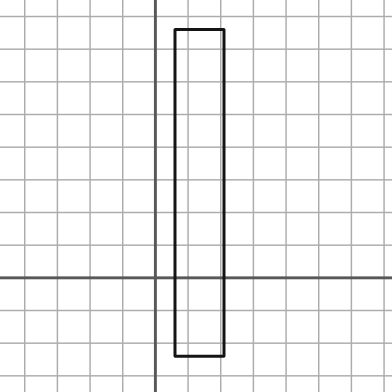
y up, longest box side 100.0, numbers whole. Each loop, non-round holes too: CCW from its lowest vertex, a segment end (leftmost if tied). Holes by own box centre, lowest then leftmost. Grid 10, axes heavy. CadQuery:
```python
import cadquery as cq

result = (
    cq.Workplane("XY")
    .moveTo(6.0, -24.0)
    .lineTo(21.0, -24.0)
    .lineTo(21.0, 76.0)
    .lineTo(6.0, 76.0)
    .close()
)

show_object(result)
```